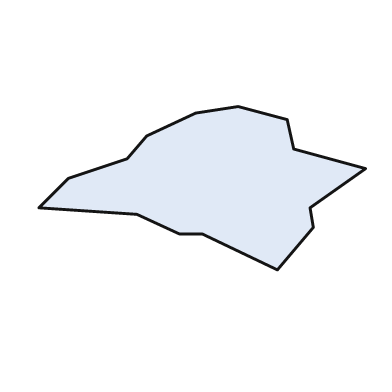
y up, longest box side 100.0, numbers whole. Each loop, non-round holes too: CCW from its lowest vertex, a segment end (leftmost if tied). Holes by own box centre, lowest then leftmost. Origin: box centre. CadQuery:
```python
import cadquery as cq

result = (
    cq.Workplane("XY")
    .moveTo(23.0, -25.0)
    .lineTo(34.0, -12.0)
    .lineTo(33.0, -6.0)
    .lineTo(50.0, 6.0)
    .lineTo(28.0, 12.0)
    .lineTo(26.0, 21.0)
    .lineTo(11.0, 25.0)
    .lineTo(-2.0, 23.0)
    .lineTo(-17.0, 16.0)
    .lineTo(-23.0, 9.0)
    .lineTo(-41.0, 3.0)
    .lineTo(-50.0, -6.0)
    .lineTo(-20.0, -8.0)
    .lineTo(-7.0, -14.0)
    .lineTo(0.0, -14.0)
    .close()
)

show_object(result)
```